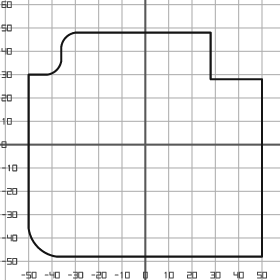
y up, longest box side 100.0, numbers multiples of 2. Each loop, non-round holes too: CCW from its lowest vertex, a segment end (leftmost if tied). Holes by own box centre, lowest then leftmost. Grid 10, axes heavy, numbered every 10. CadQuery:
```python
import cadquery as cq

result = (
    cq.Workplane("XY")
    .moveTo(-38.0, -48.0)
    .lineTo(50.0, -48.0)
    .lineTo(50.0, 28.0)
    .lineTo(28.0, 28.0)
    .lineTo(28.0, 48.0)
    .lineTo(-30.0, 48.0)
    .threePointArc((-34.0, 46.0), (-36.0, 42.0))
    .lineTo(-36.0, 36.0)
    .threePointArc((-38.0, 32.0), (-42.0, 30.0))
    .lineTo(-50.0, 30.0)
    .lineTo(-50.0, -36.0)
    .threePointArc((-46.0, -44.0), (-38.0, -48.0))
    .close()
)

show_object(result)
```